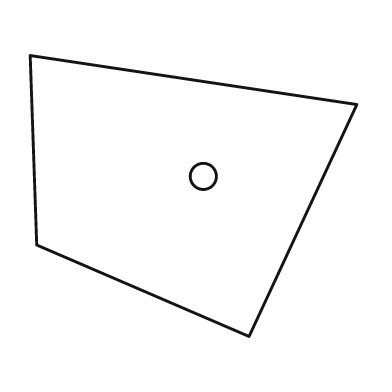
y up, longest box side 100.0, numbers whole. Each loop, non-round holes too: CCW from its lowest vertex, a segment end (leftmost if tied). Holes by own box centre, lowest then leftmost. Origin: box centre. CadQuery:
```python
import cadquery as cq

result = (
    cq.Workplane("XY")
    .moveTo(17.0, -43.0)
    .lineTo(50.0, 28.0)
    .lineTo(-50.0, 43.0)
    .lineTo(-48.0, -15.0)
    .close()
    .moveTo(3.0, 6.0)
    .circle(4.0)
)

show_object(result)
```